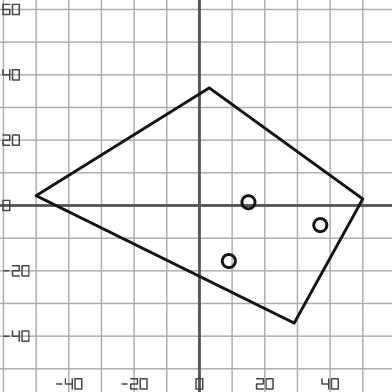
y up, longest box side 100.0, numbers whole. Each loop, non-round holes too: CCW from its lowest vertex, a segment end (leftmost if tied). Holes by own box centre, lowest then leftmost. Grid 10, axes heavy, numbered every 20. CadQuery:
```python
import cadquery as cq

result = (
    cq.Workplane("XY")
    .moveTo(29.0, -36.0)
    .lineTo(50.0, 2.0)
    .lineTo(3.0, 36.0)
    .lineTo(-50.0, 3.0)
    .close()
    .moveTo(9.0, -17.0)
    .circle(2.0)
    .moveTo(37.0, -6.0)
    .circle(2.0)
    .moveTo(15.0, 1.0)
    .circle(2.0)
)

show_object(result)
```